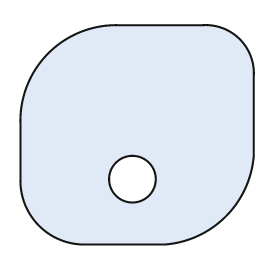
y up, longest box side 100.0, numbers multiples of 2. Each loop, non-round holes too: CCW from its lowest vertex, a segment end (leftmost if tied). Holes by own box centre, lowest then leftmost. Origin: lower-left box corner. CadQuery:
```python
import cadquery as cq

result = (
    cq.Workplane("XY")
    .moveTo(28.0, 0.0)
    .lineTo(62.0, 0.0)
    .threePointArc((88.0, 12.0), (100.0, 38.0))
    .lineTo(100.0, 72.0)
    .threePointArc((94.0, 88.0), (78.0, 94.0))
    .lineTo(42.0, 94.0)
    .threePointArc((12.0, 82.0), (0.0, 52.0))
    .lineTo(0.0, 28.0)
    .threePointArc((8.0, 8.0), (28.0, 0.0))
    .close()
    .moveTo(48.0, 28.0)
    .circle(10.0)
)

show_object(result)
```